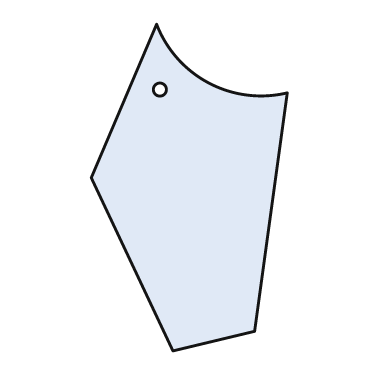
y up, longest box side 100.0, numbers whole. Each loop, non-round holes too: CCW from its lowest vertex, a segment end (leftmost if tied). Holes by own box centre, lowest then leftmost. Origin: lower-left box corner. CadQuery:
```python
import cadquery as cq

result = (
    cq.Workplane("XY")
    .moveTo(25.0, 0.0)
    .lineTo(50.0, 6.0)
    .lineTo(60.0, 79.0)
    .threePointArc((36.0, 82.0), (20.0, 100.0))
    .lineTo(0.0, 53.0)
    .close()
    .moveTo(21.0, 80.0)
    .circle(2.0)
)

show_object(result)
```